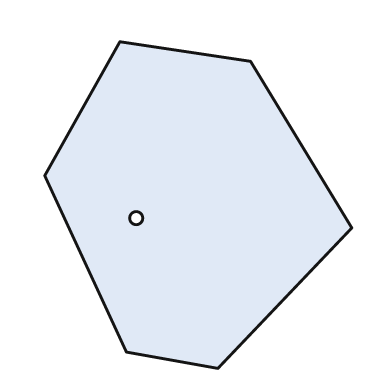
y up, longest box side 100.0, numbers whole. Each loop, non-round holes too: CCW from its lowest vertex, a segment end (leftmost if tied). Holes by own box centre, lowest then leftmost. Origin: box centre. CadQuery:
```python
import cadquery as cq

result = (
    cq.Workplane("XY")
    .moveTo(6.0, -50.0)
    .lineTo(47.0, -7.0)
    .lineTo(16.0, 44.0)
    .lineTo(-24.0, 50.0)
    .lineTo(-47.0, 9.0)
    .lineTo(-22.0, -45.0)
    .close()
    .moveTo(-19.0, -4.0)
    .circle(2.0)
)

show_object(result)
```